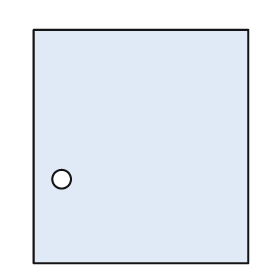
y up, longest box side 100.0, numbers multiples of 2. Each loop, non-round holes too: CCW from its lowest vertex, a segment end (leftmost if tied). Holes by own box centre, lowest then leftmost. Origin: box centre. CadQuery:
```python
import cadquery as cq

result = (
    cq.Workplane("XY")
    .moveTo(-46.0, -50.0)
    .lineTo(46.0, -50.0)
    .lineTo(46.0, 50.0)
    .lineTo(-46.0, 50.0)
    .close()
    .moveTo(-34.0, -14.0)
    .circle(4.0)
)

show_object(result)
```